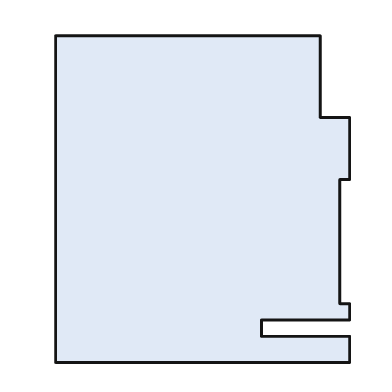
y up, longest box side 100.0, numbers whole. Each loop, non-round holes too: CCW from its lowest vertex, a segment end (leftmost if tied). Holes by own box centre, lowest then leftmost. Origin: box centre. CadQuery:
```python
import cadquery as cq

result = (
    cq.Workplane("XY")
    .moveTo(-45.0, -50.0)
    .lineTo(45.0, -50.0)
    .lineTo(45.0, -42.0)
    .lineTo(18.0, -42.0)
    .lineTo(18.0, -37.0)
    .lineTo(45.0, -37.0)
    .lineTo(45.0, -32.0)
    .lineTo(42.0, -32.0)
    .lineTo(42.0, 6.0)
    .lineTo(45.0, 6.0)
    .lineTo(45.0, 25.0)
    .lineTo(36.0, 25.0)
    .lineTo(36.0, 50.0)
    .lineTo(-45.0, 50.0)
    .close()
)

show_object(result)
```